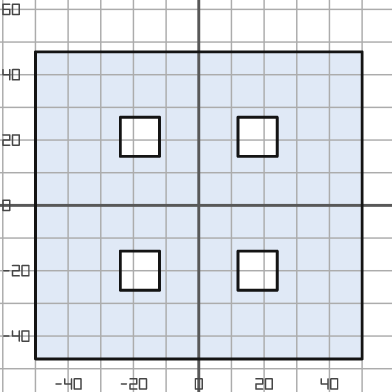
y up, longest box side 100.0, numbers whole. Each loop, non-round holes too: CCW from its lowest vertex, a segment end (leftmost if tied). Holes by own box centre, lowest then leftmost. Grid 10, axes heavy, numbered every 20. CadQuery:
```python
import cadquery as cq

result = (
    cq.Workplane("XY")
    .moveTo(-50.0, -47.0)
    .lineTo(50.0, -47.0)
    .lineTo(50.0, 47.0)
    .lineTo(-50.0, 47.0)
    .close()
    .moveTo(-24.0, -26.0)
    .lineTo(-12.0, -26.0)
    .lineTo(-12.0, -14.0)
    .lineTo(-24.0, -14.0)
    .close()
    .moveTo(12.0, -26.0)
    .lineTo(24.0, -26.0)
    .lineTo(24.0, -14.0)
    .lineTo(12.0, -14.0)
    .close()
    .moveTo(-24.0, 15.0)
    .lineTo(-12.0, 15.0)
    .lineTo(-12.0, 27.0)
    .lineTo(-24.0, 27.0)
    .close()
    .moveTo(12.0, 15.0)
    .lineTo(24.0, 15.0)
    .lineTo(24.0, 27.0)
    .lineTo(12.0, 27.0)
    .close()
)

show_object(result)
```